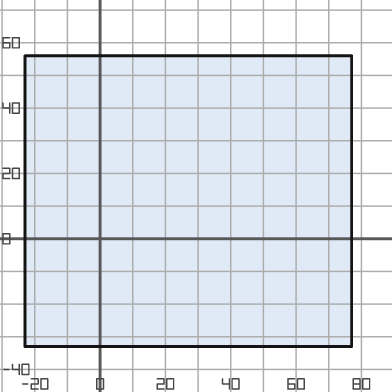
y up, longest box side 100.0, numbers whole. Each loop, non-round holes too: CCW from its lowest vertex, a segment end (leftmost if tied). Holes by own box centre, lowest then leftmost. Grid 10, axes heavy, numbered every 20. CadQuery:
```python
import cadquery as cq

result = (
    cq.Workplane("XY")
    .moveTo(-23.0, -33.0)
    .lineTo(77.0, -33.0)
    .lineTo(77.0, 56.0)
    .lineTo(-23.0, 56.0)
    .close()
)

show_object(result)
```